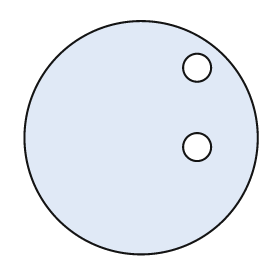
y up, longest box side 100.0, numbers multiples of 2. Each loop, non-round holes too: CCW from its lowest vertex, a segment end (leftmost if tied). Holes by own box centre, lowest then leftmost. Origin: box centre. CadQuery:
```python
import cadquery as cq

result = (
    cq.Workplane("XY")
    .moveTo(0.0, 0.0)
    .circle(50.0)
    .moveTo(24.0, -4.0)
    .circle(6.0)
    .moveTo(24.0, 30.0)
    .circle(6.0)
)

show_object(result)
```